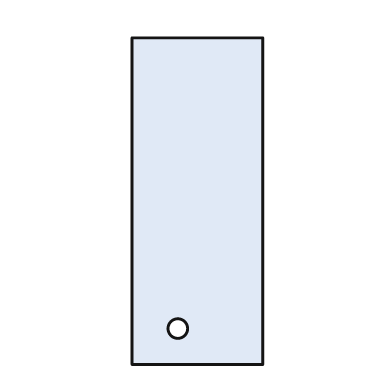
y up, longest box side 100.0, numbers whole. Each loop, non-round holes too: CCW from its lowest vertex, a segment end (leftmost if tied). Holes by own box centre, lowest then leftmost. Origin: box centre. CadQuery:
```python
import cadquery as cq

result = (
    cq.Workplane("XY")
    .moveTo(-20.0, -50.0)
    .lineTo(20.0, -50.0)
    .lineTo(20.0, 50.0)
    .lineTo(-20.0, 50.0)
    .close()
    .moveTo(-6.0, -39.0)
    .circle(3.0)
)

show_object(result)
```